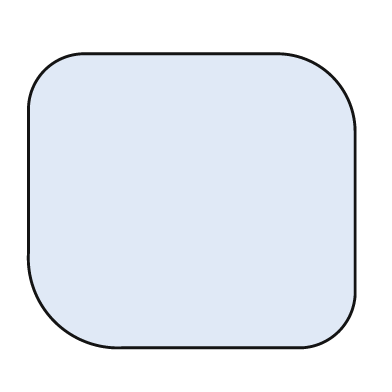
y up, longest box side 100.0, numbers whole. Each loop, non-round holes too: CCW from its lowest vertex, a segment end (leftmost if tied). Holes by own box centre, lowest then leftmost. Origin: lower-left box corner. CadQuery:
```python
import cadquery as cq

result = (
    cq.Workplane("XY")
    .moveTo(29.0, 0.0)
    .lineTo(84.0, 0.0)
    .threePointArc((95.0, 5.0), (100.0, 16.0))
    .lineTo(100.0, 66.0)
    .threePointArc((93.0, 83.0), (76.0, 90.0))
    .lineTo(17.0, 90.0)
    .threePointArc((5.0, 85.0), (0.0, 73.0))
    .lineTo(0.0, 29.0)
    .threePointArc((8.0, 8.0), (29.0, 0.0))
    .close()
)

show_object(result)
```